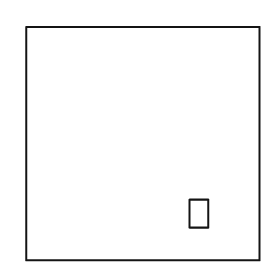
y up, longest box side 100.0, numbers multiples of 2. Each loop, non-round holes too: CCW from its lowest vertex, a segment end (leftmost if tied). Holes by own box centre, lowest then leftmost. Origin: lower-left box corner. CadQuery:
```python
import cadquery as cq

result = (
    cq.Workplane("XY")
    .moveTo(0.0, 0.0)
    .lineTo(100.0, 0.0)
    .lineTo(100.0, 100.0)
    .lineTo(0.0, 100.0)
    .close()
    .moveTo(70.0, 14.0)
    .lineTo(78.0, 14.0)
    .lineTo(78.0, 26.0)
    .lineTo(70.0, 26.0)
    .close()
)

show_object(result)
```